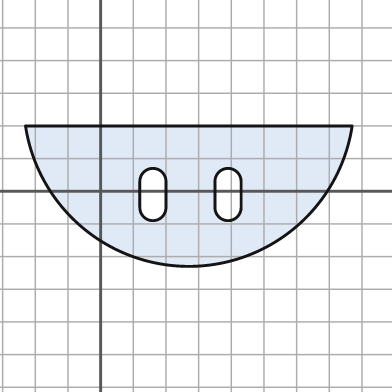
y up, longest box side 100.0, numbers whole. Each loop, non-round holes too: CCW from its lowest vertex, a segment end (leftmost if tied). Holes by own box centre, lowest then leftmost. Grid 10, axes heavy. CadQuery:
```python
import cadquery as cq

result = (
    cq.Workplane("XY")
    .moveTo(-23.0, 20.0)
    .threePointArc((27.0, -23.0), (77.0, 20.0))
    .close()
    .moveTo(12.0, -5.0)
    .threePointArc((16.0, -9.0), (20.0, -5.0))
    .lineTo(20.0, 3.0)
    .threePointArc((16.0, 7.0), (12.0, 3.0))
    .close()
    .moveTo(35.0, -5.0)
    .threePointArc((39.0, -9.0), (43.0, -5.0))
    .lineTo(43.0, 3.0)
    .threePointArc((39.0, 7.0), (35.0, 3.0))
    .close()
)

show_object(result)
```